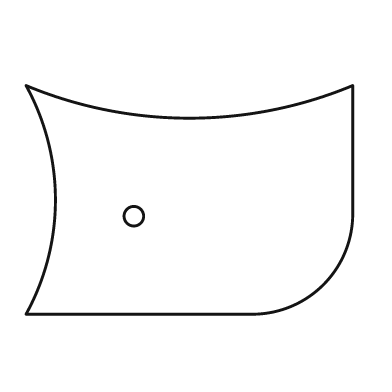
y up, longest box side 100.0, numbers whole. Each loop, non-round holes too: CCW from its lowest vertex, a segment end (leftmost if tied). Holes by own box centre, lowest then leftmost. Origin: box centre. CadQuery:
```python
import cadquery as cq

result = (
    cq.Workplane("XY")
    .moveTo(-50.0, -35.0)
    .lineTo(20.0, -35.0)
    .threePointArc((41.0, -26.0), (50.0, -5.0))
    .lineTo(50.0, 35.0)
    .threePointArc((0.0, 25.0), (-50.0, 35.0))
    .threePointArc((-41.0, 0.0), (-50.0, -35.0))
    .close()
    .moveTo(-17.0, -5.0)
    .circle(3.0)
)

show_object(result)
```